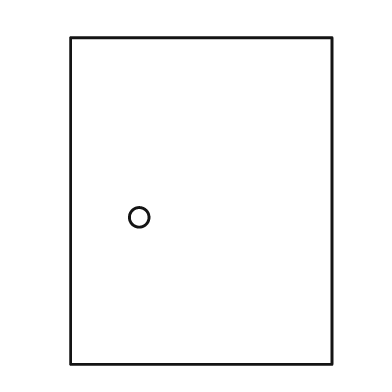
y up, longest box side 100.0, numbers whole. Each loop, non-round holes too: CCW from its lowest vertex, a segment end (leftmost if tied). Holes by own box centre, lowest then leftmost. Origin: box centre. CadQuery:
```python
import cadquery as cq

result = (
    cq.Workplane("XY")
    .moveTo(-40.0, -50.0)
    .lineTo(40.0, -50.0)
    .lineTo(40.0, 50.0)
    .lineTo(-40.0, 50.0)
    .close()
    .moveTo(-19.0, -5.0)
    .circle(3.0)
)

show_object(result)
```